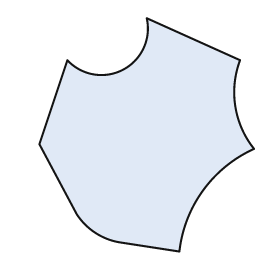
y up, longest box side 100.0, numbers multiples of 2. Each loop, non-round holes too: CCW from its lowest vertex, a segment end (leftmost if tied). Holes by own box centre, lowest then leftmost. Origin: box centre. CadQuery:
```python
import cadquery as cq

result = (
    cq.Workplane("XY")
    .moveTo(14.0, -50.0)
    .threePointArc((24.0, -24.0), (46.0, -6.0))
    .threePointArc((38.0, 12.0), (40.0, 32.0))
    .lineTo(0.0, 50.0)
    .threePointArc((-10.0, 28.0), (-34.0, 32.0))
    .lineTo(-46.0, -4.0)
    .lineTo(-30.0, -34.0)
    .threePointArc((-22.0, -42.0), (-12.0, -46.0))
    .close()
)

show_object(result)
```